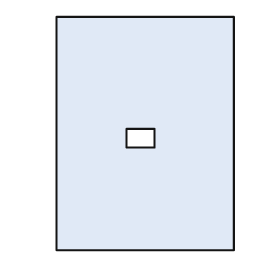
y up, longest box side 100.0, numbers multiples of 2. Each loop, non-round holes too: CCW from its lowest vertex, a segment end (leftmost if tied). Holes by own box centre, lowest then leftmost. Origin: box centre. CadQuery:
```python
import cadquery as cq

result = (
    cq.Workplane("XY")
    .moveTo(-38.0, -50.0)
    .lineTo(38.0, -50.0)
    .lineTo(38.0, 50.0)
    .lineTo(-38.0, 50.0)
    .close()
    .moveTo(-8.0, -6.0)
    .lineTo(4.0, -6.0)
    .lineTo(4.0, 2.0)
    .lineTo(-8.0, 2.0)
    .close()
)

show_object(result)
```